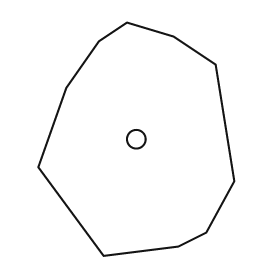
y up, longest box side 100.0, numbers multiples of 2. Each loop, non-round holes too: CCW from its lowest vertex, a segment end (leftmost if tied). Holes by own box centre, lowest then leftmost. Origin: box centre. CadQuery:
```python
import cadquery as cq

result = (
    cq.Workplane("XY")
    .moveTo(-14.0, -50.0)
    .lineTo(18.0, -46.0)
    .lineTo(30.0, -40.0)
    .lineTo(42.0, -18.0)
    .lineTo(34.0, 32.0)
    .lineTo(16.0, 44.0)
    .lineTo(-4.0, 50.0)
    .lineTo(-16.0, 42.0)
    .lineTo(-30.0, 22.0)
    .lineTo(-42.0, -12.0)
    .close()
    .moveTo(0.0, 0.0)
    .circle(4.0)
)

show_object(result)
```